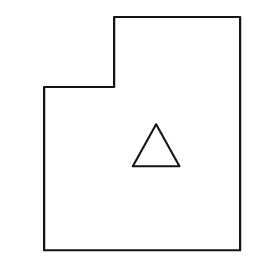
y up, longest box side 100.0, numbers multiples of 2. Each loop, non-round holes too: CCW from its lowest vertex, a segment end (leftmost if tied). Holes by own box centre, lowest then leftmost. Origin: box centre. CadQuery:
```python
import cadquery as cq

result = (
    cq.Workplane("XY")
    .moveTo(-42.0, -50.0)
    .lineTo(42.0, -50.0)
    .lineTo(42.0, 50.0)
    .lineTo(-12.0, 50.0)
    .lineTo(-12.0, 20.0)
    .lineTo(-42.0, 20.0)
    .close()
    .moveTo(-4.0, -14.0)
    .lineTo(16.0, -14.0)
    .lineTo(6.0, 4.0)
    .close()
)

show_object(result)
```